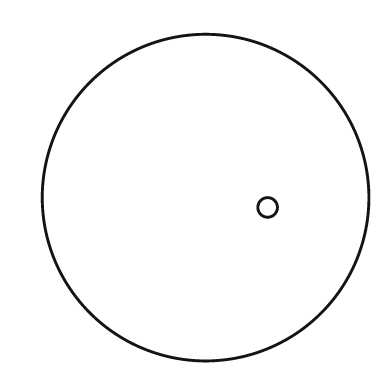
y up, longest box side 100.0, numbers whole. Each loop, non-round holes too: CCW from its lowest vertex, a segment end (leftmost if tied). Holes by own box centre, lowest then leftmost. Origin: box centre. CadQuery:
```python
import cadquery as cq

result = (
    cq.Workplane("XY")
    .moveTo(0.0, 0.0)
    .circle(50.0)
    .moveTo(19.0, -3.0)
    .circle(3.0)
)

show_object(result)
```